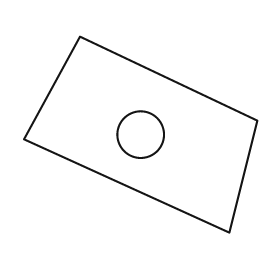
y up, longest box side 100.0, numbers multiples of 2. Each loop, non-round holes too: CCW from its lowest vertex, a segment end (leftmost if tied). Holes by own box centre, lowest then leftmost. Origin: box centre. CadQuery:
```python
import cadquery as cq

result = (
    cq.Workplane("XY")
    .moveTo(38.0, -42.0)
    .lineTo(50.0, 6.0)
    .lineTo(-26.0, 42.0)
    .lineTo(-50.0, -2.0)
    .close()
    .moveTo(0.0, 0.0)
    .circle(10.0)
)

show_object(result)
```